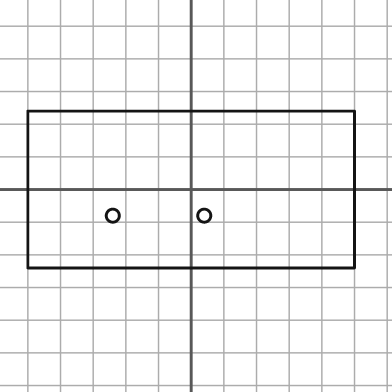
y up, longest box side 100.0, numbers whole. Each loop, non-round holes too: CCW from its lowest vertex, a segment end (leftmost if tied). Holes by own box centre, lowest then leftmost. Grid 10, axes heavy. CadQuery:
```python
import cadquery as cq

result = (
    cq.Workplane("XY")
    .moveTo(-50.0, -24.0)
    .lineTo(50.0, -24.0)
    .lineTo(50.0, 24.0)
    .lineTo(-50.0, 24.0)
    .close()
    .moveTo(-24.0, -8.0)
    .circle(2.0)
    .moveTo(4.0, -8.0)
    .circle(2.0)
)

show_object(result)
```